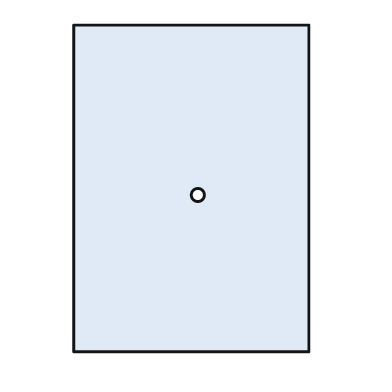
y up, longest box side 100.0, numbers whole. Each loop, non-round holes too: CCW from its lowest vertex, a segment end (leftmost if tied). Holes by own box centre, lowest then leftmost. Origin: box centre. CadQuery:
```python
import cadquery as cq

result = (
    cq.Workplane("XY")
    .moveTo(-36.0, -50.0)
    .lineTo(36.0, -50.0)
    .lineTo(36.0, 50.0)
    .lineTo(-36.0, 50.0)
    .close()
    .moveTo(2.0, -2.0)
    .circle(2.0)
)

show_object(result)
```